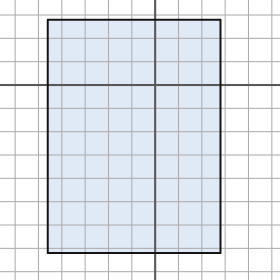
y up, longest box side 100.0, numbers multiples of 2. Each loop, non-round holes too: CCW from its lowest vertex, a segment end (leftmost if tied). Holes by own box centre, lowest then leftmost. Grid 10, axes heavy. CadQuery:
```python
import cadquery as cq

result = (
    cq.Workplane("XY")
    .moveTo(-46.0, -72.0)
    .lineTo(28.0, -72.0)
    .lineTo(28.0, 28.0)
    .lineTo(-46.0, 28.0)
    .close()
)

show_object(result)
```